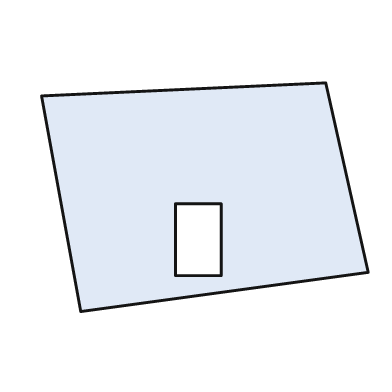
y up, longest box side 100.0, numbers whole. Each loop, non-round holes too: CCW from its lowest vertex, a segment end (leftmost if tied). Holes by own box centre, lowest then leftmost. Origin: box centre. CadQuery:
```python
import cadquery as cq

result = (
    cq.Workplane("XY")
    .moveTo(-38.0, -35.0)
    .lineTo(50.0, -23.0)
    .lineTo(37.0, 35.0)
    .lineTo(-50.0, 31.0)
    .close()
    .moveTo(-9.0, -24.0)
    .lineTo(5.0, -24.0)
    .lineTo(5.0, -2.0)
    .lineTo(-9.0, -2.0)
    .close()
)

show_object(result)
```